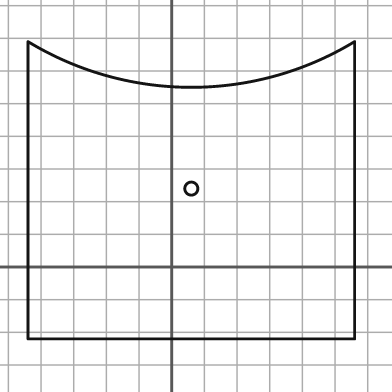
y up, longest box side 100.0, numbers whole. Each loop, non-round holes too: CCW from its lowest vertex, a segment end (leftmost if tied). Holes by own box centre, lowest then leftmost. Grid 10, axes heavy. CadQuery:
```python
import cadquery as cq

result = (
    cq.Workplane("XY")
    .moveTo(-44.0, -22.0)
    .lineTo(56.0, -22.0)
    .lineTo(56.0, 69.0)
    .threePointArc((6.0, 55.0), (-44.0, 69.0))
    .close()
    .moveTo(6.0, 24.0)
    .circle(2.0)
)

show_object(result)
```